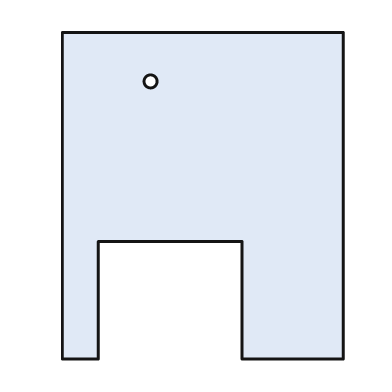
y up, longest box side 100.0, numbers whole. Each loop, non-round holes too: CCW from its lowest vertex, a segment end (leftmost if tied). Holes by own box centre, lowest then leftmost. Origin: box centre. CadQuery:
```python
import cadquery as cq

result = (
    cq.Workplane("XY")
    .moveTo(-43.0, -50.0)
    .lineTo(-32.0, -50.0)
    .lineTo(-32.0, -14.0)
    .lineTo(12.0, -14.0)
    .lineTo(12.0, -50.0)
    .lineTo(43.0, -50.0)
    .lineTo(43.0, 50.0)
    .lineTo(-43.0, 50.0)
    .close()
    .moveTo(-16.0, 35.0)
    .circle(2.0)
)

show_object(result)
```